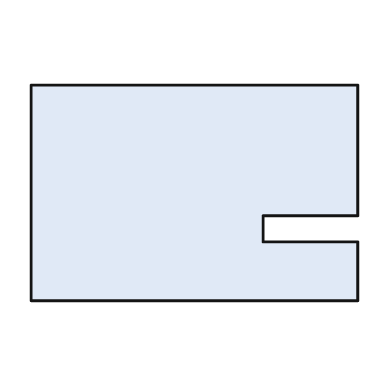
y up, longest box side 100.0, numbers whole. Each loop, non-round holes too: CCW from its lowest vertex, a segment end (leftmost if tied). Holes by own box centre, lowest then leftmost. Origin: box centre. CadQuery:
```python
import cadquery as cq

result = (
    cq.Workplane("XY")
    .moveTo(-50.0, -33.0)
    .lineTo(50.0, -33.0)
    .lineTo(50.0, -15.0)
    .lineTo(21.0, -15.0)
    .lineTo(21.0, -7.0)
    .lineTo(50.0, -7.0)
    .lineTo(50.0, 33.0)
    .lineTo(-50.0, 33.0)
    .close()
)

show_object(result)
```